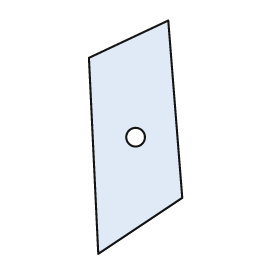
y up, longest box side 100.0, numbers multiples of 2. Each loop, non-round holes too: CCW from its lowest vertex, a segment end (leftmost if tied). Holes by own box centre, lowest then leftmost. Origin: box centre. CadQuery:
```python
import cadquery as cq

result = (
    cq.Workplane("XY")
    .moveTo(-16.0, -50.0)
    .lineTo(20.0, -26.0)
    .lineTo(14.0, 50.0)
    .lineTo(-20.0, 34.0)
    .close()
    .moveTo(0.0, 0.0)
    .circle(4.0)
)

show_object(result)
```